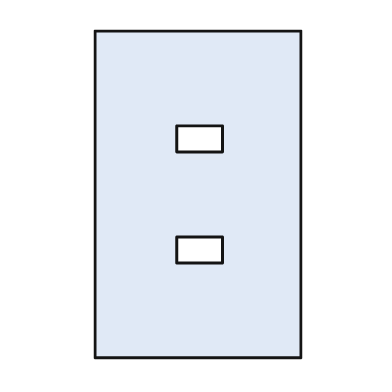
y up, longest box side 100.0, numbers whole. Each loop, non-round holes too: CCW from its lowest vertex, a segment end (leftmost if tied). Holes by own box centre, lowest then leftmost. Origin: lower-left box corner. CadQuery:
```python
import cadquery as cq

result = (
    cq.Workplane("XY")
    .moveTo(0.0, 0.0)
    .lineTo(63.0, 0.0)
    .lineTo(63.0, 100.0)
    .lineTo(0.0, 100.0)
    .close()
    .moveTo(25.0, 29.0)
    .lineTo(39.0, 29.0)
    .lineTo(39.0, 37.0)
    .lineTo(25.0, 37.0)
    .close()
    .moveTo(25.0, 63.0)
    .lineTo(39.0, 63.0)
    .lineTo(39.0, 71.0)
    .lineTo(25.0, 71.0)
    .close()
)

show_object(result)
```